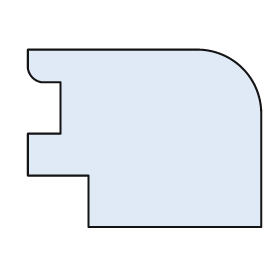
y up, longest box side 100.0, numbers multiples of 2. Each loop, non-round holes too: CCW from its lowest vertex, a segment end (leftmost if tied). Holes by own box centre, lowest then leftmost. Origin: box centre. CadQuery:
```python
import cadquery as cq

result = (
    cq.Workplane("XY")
    .moveTo(-24.0, -38.0)
    .lineTo(50.0, -38.0)
    .lineTo(50.0, 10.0)
    .threePointArc((42.0, 30.0), (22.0, 38.0))
    .lineTo(-50.0, 38.0)
    .lineTo(-50.0, 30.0)
    .threePointArc((-48.0, 26.0), (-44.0, 24.0))
    .lineTo(-36.0, 24.0)
    .lineTo(-36.0, 2.0)
    .lineTo(-50.0, 2.0)
    .lineTo(-50.0, -16.0)
    .lineTo(-24.0, -16.0)
    .close()
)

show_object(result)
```